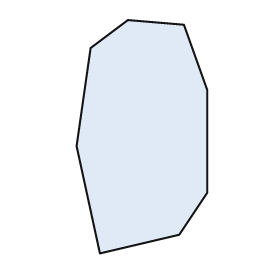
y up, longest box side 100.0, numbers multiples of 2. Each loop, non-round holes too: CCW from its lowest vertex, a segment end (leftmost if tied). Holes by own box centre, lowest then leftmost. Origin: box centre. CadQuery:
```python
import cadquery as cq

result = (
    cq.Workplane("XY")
    .moveTo(-18.0, -50.0)
    .lineTo(16.0, -42.0)
    .lineTo(28.0, -24.0)
    .lineTo(28.0, 20.0)
    .lineTo(18.0, 48.0)
    .lineTo(-6.0, 50.0)
    .lineTo(-22.0, 38.0)
    .lineTo(-28.0, -4.0)
    .close()
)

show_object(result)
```